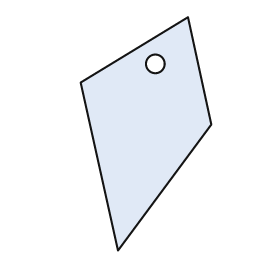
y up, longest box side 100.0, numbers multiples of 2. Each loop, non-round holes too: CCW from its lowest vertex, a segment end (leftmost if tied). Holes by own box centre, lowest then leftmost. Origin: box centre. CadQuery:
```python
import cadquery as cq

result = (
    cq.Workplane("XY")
    .moveTo(-12.0, -50.0)
    .lineTo(28.0, 4.0)
    .lineTo(18.0, 50.0)
    .lineTo(-28.0, 22.0)
    .close()
    .moveTo(4.0, 30.0)
    .circle(4.0)
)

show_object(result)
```